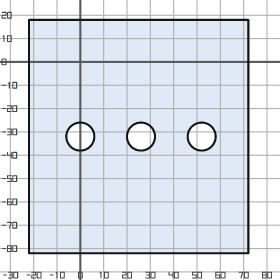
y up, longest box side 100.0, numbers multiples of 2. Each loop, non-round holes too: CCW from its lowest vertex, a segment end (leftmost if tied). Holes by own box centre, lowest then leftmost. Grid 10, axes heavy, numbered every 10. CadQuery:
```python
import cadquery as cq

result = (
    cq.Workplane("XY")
    .moveTo(-22.0, -82.0)
    .lineTo(72.0, -82.0)
    .lineTo(72.0, 18.0)
    .lineTo(-22.0, 18.0)
    .close()
    .moveTo(0.0, -32.0)
    .circle(6.0)
    .moveTo(26.0, -32.0)
    .circle(6.0)
    .moveTo(52.0, -32.0)
    .circle(6.0)
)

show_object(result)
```